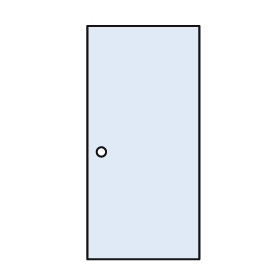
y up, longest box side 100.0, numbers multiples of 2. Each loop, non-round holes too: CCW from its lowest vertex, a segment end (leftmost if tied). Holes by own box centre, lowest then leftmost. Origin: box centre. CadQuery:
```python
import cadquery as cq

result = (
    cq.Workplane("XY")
    .moveTo(-24.0, -50.0)
    .lineTo(24.0, -50.0)
    .lineTo(24.0, 50.0)
    .lineTo(-24.0, 50.0)
    .close()
    .moveTo(-18.0, -4.0)
    .circle(2.0)
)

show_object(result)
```